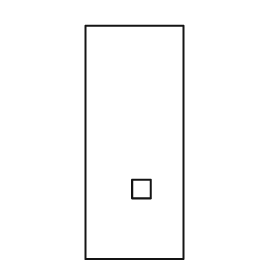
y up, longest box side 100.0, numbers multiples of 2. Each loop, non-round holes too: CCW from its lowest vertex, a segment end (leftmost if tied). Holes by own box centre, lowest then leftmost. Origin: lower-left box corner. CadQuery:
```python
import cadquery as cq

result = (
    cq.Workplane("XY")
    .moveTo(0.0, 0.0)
    .lineTo(42.0, 0.0)
    .lineTo(42.0, 100.0)
    .lineTo(0.0, 100.0)
    .close()
    .moveTo(20.0, 26.0)
    .lineTo(28.0, 26.0)
    .lineTo(28.0, 34.0)
    .lineTo(20.0, 34.0)
    .close()
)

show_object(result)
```